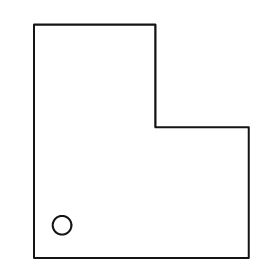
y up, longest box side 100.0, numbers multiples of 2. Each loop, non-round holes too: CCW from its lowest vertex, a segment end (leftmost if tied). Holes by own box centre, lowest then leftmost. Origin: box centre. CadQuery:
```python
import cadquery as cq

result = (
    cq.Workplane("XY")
    .moveTo(-46.0, -50.0)
    .lineTo(46.0, -50.0)
    .lineTo(46.0, 6.0)
    .lineTo(6.0, 6.0)
    .lineTo(6.0, 50.0)
    .lineTo(-46.0, 50.0)
    .close()
    .moveTo(-34.0, -36.0)
    .circle(4.0)
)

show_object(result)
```